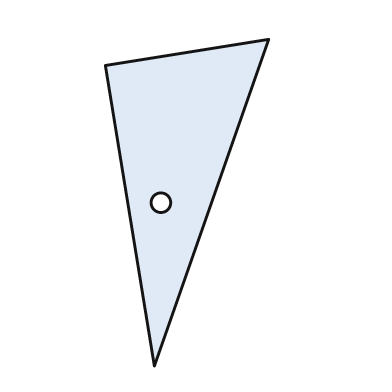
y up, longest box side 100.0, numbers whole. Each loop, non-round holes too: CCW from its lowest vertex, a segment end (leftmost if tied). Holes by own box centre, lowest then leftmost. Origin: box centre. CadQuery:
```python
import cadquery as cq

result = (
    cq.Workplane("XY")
    .moveTo(-10.0, -50.0)
    .lineTo(25.0, 50.0)
    .lineTo(-25.0, 42.0)
    .close()
    .moveTo(-8.0, 0.0)
    .circle(3.0)
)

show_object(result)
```